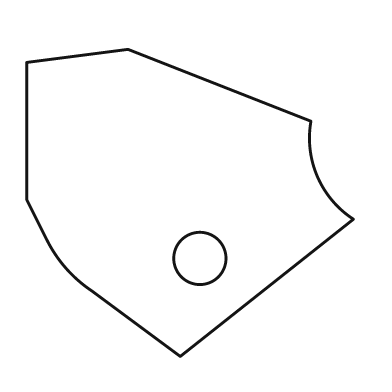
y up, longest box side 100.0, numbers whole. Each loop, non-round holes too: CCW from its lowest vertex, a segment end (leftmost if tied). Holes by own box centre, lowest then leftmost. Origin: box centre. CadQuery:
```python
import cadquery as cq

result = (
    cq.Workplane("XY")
    .moveTo(-3.0, -47.0)
    .lineTo(50.0, -5.0)
    .threePointArc((39.0, 8.0), (37.0, 25.0))
    .lineTo(-19.0, 47.0)
    .lineTo(-50.0, 43.0)
    .lineTo(-50.0, 1.0)
    .lineTo(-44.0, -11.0)
    .threePointArc((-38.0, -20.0), (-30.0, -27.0))
    .close()
    .moveTo(3.0, -17.0)
    .circle(8.0)
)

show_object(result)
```